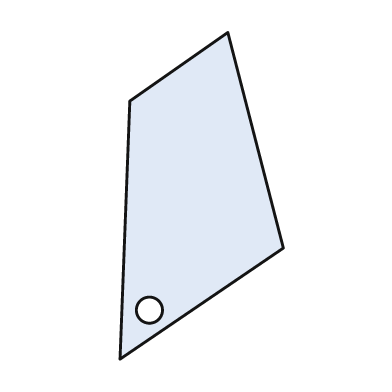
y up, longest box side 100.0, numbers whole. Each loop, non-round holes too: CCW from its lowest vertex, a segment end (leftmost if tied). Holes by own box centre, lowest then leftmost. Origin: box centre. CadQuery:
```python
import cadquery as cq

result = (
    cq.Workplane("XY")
    .moveTo(-25.0, -50.0)
    .lineTo(25.0, -16.0)
    .lineTo(8.0, 50.0)
    .lineTo(-22.0, 29.0)
    .close()
    .moveTo(-16.0, -35.0)
    .circle(4.0)
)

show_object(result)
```